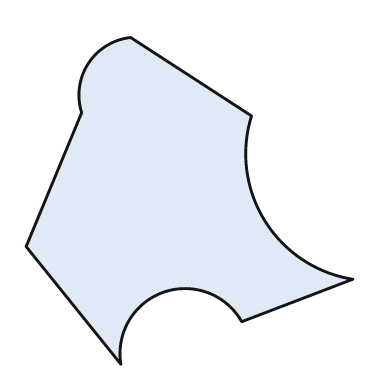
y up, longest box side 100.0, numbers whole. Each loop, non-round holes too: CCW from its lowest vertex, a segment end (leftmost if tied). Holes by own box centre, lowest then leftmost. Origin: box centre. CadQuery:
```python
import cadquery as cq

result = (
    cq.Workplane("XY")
    .moveTo(-21.0, -50.0)
    .threePointArc((-8.0, -28.0), (16.0, -37.0))
    .lineTo(50.0, -24.0)
    .threePointArc((23.0, -6.0), (19.0, 26.0))
    .lineTo(-18.0, 50.0)
    .threePointArc((-31.0, 42.0), (-33.0, 27.0))
    .lineTo(-50.0, -14.0)
    .close()
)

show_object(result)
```